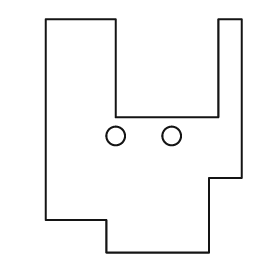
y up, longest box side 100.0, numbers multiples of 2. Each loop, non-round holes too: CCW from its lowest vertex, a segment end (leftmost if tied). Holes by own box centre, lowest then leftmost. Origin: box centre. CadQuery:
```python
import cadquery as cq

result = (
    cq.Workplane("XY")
    .moveTo(-16.0, -50.0)
    .lineTo(28.0, -50.0)
    .lineTo(28.0, -18.0)
    .lineTo(42.0, -18.0)
    .lineTo(42.0, 50.0)
    .lineTo(32.0, 50.0)
    .lineTo(32.0, 8.0)
    .lineTo(-12.0, 8.0)
    .lineTo(-12.0, 50.0)
    .lineTo(-42.0, 50.0)
    .lineTo(-42.0, -36.0)
    .lineTo(-16.0, -36.0)
    .close()
    .moveTo(-12.0, 0.0)
    .circle(4.0)
    .moveTo(12.0, 0.0)
    .circle(4.0)
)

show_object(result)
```